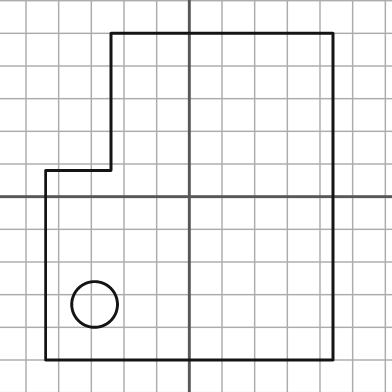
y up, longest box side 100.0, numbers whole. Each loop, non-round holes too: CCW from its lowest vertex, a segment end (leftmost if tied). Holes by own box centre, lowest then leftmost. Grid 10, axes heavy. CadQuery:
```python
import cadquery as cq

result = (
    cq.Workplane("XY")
    .moveTo(-44.0, -50.0)
    .lineTo(44.0, -50.0)
    .lineTo(44.0, 50.0)
    .lineTo(-24.0, 50.0)
    .lineTo(-24.0, 8.0)
    .lineTo(-44.0, 8.0)
    .close()
    .moveTo(-29.0, -33.0)
    .circle(7.0)
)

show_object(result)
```